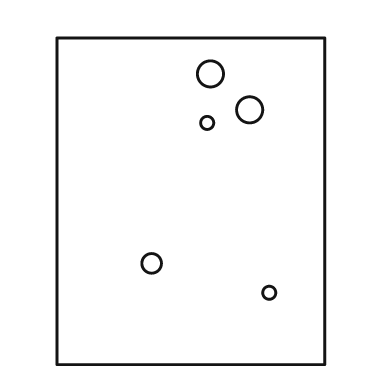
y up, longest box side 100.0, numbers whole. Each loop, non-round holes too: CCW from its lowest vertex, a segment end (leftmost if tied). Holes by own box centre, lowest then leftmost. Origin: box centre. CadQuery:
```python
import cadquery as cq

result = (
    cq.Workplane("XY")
    .moveTo(-41.0, -50.0)
    .lineTo(41.0, -50.0)
    .lineTo(41.0, 50.0)
    .lineTo(-41.0, 50.0)
    .close()
    .moveTo(24.0, -28.0)
    .circle(2.0)
    .moveTo(-12.0, -19.0)
    .circle(3.0)
    .moveTo(5.0, 24.0)
    .circle(2.0)
    .moveTo(18.0, 28.0)
    .circle(4.0)
    .moveTo(6.0, 39.0)
    .circle(4.0)
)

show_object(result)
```